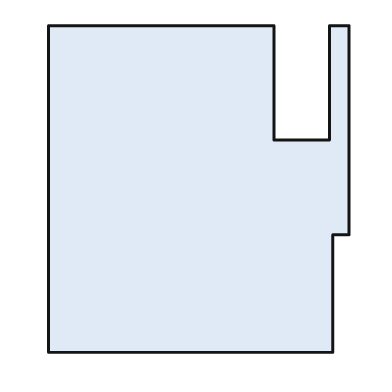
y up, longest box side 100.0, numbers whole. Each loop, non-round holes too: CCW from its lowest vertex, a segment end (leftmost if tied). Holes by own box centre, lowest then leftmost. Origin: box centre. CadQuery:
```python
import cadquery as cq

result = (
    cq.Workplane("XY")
    .moveTo(-46.0, -50.0)
    .lineTo(41.0, -50.0)
    .lineTo(41.0, -14.0)
    .lineTo(46.0, -14.0)
    .lineTo(46.0, 50.0)
    .lineTo(40.0, 50.0)
    .lineTo(40.0, 15.0)
    .lineTo(23.0, 15.0)
    .lineTo(23.0, 50.0)
    .lineTo(-46.0, 50.0)
    .close()
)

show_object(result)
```